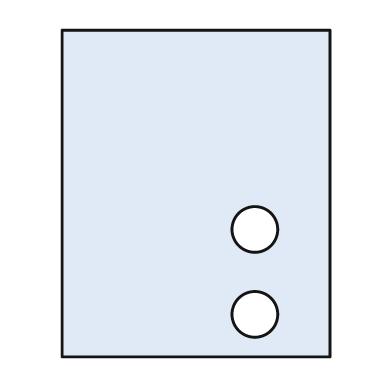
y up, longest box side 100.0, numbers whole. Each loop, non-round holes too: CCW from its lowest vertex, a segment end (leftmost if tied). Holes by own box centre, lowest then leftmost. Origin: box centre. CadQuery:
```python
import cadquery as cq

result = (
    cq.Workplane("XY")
    .moveTo(-41.0, -50.0)
    .lineTo(41.0, -50.0)
    .lineTo(41.0, 50.0)
    .lineTo(-41.0, 50.0)
    .close()
    .moveTo(18.0, -37.0)
    .circle(7.0)
    .moveTo(18.0, -11.0)
    .circle(7.0)
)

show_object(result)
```